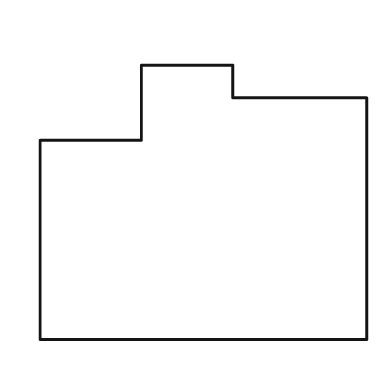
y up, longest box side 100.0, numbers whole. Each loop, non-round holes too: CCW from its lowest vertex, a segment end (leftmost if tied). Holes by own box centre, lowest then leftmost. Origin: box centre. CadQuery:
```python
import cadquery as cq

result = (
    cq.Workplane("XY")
    .moveTo(-50.0, -42.0)
    .lineTo(50.0, -42.0)
    .lineTo(50.0, 32.0)
    .lineTo(9.0, 32.0)
    .lineTo(9.0, 42.0)
    .lineTo(-19.0, 42.0)
    .lineTo(-19.0, 19.0)
    .lineTo(-50.0, 19.0)
    .close()
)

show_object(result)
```